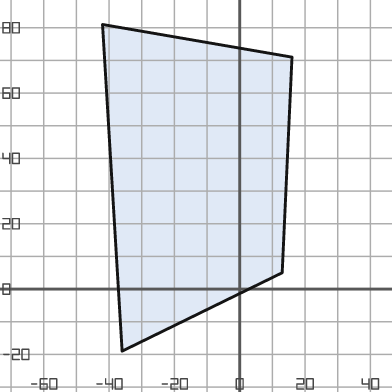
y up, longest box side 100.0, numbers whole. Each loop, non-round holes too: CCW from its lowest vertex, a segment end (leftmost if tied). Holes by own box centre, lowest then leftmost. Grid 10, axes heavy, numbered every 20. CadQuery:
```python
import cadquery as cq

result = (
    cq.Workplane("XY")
    .moveTo(-36.0, -19.0)
    .lineTo(13.0, 5.0)
    .lineTo(16.0, 71.0)
    .lineTo(-42.0, 81.0)
    .close()
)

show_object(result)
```